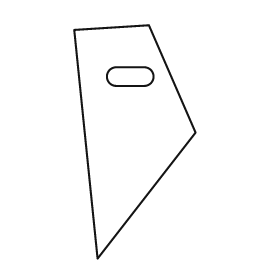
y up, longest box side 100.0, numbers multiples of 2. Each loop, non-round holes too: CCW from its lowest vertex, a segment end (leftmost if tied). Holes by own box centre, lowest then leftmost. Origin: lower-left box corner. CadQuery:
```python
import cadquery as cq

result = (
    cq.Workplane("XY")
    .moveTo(10.0, 0.0)
    .lineTo(52.0, 54.0)
    .lineTo(32.0, 100.0)
    .lineTo(0.0, 98.0)
    .close()
    .moveTo(18.0, 74.0)
    .lineTo(30.0, 74.0)
    .threePointArc((34.0, 78.0), (30.0, 82.0))
    .lineTo(18.0, 82.0)
    .threePointArc((14.0, 78.0), (18.0, 74.0))
    .close()
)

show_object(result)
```